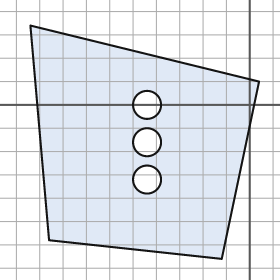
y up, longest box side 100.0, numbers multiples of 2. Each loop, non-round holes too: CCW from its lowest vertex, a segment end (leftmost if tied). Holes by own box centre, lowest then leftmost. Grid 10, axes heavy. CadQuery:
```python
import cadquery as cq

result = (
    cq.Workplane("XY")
    .moveTo(-12.0, -66.0)
    .lineTo(4.0, 10.0)
    .lineTo(-94.0, 34.0)
    .lineTo(-86.0, -58.0)
    .close()
    .moveTo(-44.0, -32.0)
    .circle(6.0)
    .moveTo(-44.0, -16.0)
    .circle(6.0)
    .moveTo(-44.0, 0.0)
    .circle(6.0)
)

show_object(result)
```